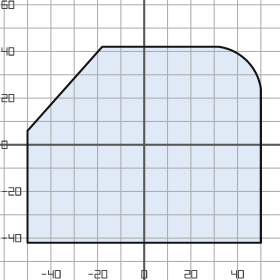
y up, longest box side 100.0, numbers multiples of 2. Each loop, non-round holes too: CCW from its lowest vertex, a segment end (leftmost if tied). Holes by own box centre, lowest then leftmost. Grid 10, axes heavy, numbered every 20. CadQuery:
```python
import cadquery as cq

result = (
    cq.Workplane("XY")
    .moveTo(-50.0, -42.0)
    .lineTo(50.0, -42.0)
    .lineTo(50.0, 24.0)
    .threePointArc((44.0, 36.0), (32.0, 42.0))
    .lineTo(-18.0, 42.0)
    .lineTo(-50.0, 6.0)
    .close()
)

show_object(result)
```